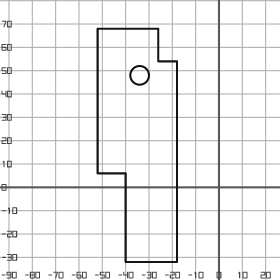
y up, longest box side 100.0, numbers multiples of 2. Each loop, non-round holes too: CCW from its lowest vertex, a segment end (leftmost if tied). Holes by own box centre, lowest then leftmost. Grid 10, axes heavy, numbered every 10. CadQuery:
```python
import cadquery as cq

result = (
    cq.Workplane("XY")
    .moveTo(-40.0, -32.0)
    .lineTo(-18.0, -32.0)
    .lineTo(-18.0, 54.0)
    .lineTo(-26.0, 54.0)
    .lineTo(-26.0, 68.0)
    .lineTo(-52.0, 68.0)
    .lineTo(-52.0, 6.0)
    .lineTo(-40.0, 6.0)
    .close()
    .moveTo(-34.0, 48.0)
    .circle(4.0)
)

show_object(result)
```